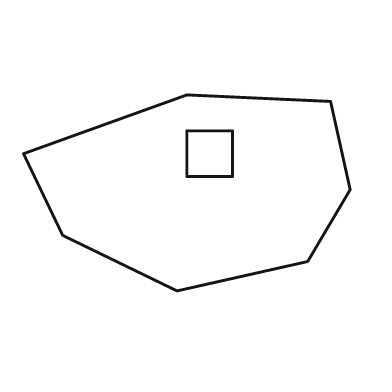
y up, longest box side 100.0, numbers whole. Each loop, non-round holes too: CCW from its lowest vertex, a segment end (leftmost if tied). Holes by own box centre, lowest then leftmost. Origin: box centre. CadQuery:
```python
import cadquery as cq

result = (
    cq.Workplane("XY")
    .moveTo(-3.0, -30.0)
    .lineTo(37.0, -21.0)
    .lineTo(50.0, 1.0)
    .lineTo(44.0, 28.0)
    .lineTo(0.0, 30.0)
    .lineTo(-50.0, 12.0)
    .lineTo(-38.0, -13.0)
    .close()
    .moveTo(0.0, 5.0)
    .lineTo(14.0, 5.0)
    .lineTo(14.0, 19.0)
    .lineTo(0.0, 19.0)
    .close()
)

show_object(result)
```